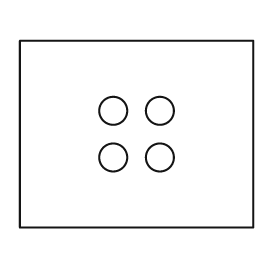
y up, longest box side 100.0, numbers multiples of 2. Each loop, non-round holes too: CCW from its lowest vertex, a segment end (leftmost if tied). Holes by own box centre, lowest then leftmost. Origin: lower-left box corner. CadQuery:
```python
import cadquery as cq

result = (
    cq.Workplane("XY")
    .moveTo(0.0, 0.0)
    .lineTo(100.0, 0.0)
    .lineTo(100.0, 80.0)
    .lineTo(0.0, 80.0)
    .close()
    .moveTo(40.0, 30.0)
    .circle(6.0)
    .moveTo(60.0, 30.0)
    .circle(6.0)
    .moveTo(40.0, 50.0)
    .circle(6.0)
    .moveTo(60.0, 50.0)
    .circle(6.0)
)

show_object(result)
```